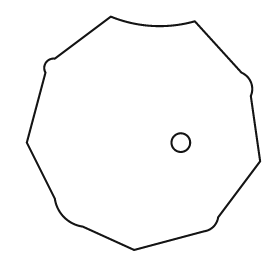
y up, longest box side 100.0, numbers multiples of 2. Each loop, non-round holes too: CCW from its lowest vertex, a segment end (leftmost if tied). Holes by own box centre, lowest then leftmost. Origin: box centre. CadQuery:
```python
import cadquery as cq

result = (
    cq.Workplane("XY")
    .moveTo(-4.0, -50.0)
    .lineTo(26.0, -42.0)
    .threePointArc((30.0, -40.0), (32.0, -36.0))
    .lineTo(50.0, -12.0)
    .lineTo(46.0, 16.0)
    .threePointArc((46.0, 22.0), (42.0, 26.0))
    .lineTo(22.0, 48.0)
    .threePointArc((4.0, 46.0), (-14.0, 50.0))
    .lineTo(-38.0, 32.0)
    .threePointArc((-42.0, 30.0), (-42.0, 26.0))
    .lineTo(-50.0, -4.0)
    .lineTo(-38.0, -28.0)
    .threePointArc((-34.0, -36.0), (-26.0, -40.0))
    .close()
    .moveTo(16.0, -4.0)
    .circle(4.0)
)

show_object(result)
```